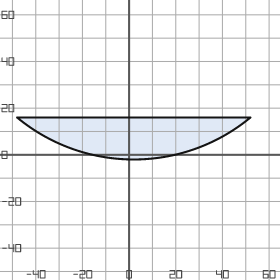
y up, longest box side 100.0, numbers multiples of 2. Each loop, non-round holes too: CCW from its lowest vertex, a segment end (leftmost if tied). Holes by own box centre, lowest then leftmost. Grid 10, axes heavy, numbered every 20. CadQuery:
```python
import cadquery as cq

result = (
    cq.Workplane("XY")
    .moveTo(-48.0, 16.0)
    .threePointArc((2.0, -2.0), (52.0, 16.0))
    .close()
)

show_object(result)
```